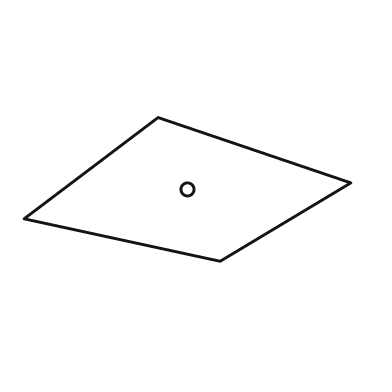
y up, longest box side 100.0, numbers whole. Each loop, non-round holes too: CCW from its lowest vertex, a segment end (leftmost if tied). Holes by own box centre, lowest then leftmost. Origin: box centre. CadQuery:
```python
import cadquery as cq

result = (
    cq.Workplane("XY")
    .moveTo(10.0, -22.0)
    .lineTo(50.0, 2.0)
    .lineTo(-9.0, 22.0)
    .lineTo(-50.0, -9.0)
    .close()
    .moveTo(0.0, 0.0)
    .circle(2.0)
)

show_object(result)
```